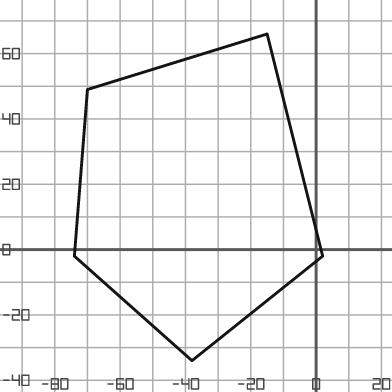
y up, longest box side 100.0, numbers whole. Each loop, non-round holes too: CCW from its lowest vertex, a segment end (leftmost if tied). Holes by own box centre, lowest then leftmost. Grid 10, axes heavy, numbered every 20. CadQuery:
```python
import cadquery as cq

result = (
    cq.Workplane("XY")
    .moveTo(-38.0, -34.0)
    .lineTo(2.0, -2.0)
    .lineTo(-15.0, 66.0)
    .lineTo(-70.0, 49.0)
    .lineTo(-74.0, -2.0)
    .close()
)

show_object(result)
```